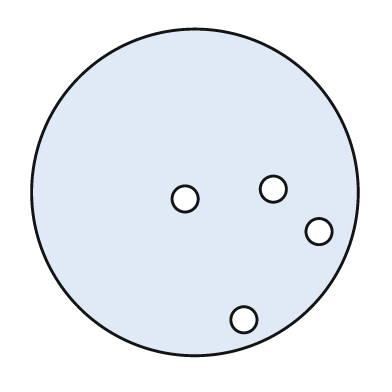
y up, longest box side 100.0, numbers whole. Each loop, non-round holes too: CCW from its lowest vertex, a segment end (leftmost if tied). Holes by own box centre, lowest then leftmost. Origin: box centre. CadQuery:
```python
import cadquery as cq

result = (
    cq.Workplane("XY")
    .moveTo(0.0, 0.0)
    .circle(50.0)
    .moveTo(15.0, -39.0)
    .circle(4.0)
    .moveTo(38.0, -12.0)
    .circle(4.0)
    .moveTo(-3.0, -2.0)
    .circle(4.0)
    .moveTo(24.0, 1.0)
    .circle(4.0)
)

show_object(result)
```